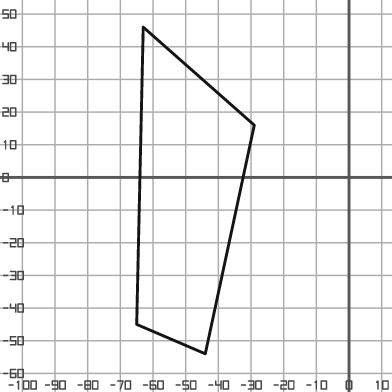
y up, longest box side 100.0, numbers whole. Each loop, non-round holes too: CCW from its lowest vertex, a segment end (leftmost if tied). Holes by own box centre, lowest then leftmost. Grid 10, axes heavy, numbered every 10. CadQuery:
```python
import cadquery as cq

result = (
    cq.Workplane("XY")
    .moveTo(-44.0, -54.0)
    .lineTo(-29.0, 16.0)
    .lineTo(-63.0, 46.0)
    .lineTo(-65.0, -45.0)
    .close()
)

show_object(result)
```